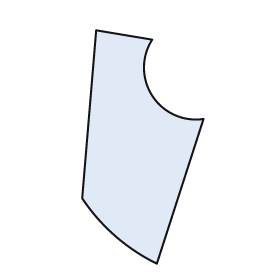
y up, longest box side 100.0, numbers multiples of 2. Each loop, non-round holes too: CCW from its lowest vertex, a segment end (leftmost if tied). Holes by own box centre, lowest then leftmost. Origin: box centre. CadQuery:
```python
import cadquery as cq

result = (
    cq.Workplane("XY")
    .moveTo(6.0, -50.0)
    .lineTo(26.0, 12.0)
    .threePointArc((4.0, 22.0), (4.0, 46.0))
    .lineTo(-20.0, 50.0)
    .lineTo(-26.0, -22.0)
    .threePointArc((-12.0, -38.0), (6.0, -50.0))
    .close()
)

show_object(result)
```